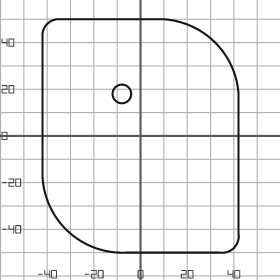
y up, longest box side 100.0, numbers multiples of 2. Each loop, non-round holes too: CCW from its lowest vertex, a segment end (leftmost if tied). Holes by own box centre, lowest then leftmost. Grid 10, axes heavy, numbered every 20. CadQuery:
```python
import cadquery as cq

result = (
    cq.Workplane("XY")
    .moveTo(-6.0, -50.0)
    .lineTo(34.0, -50.0)
    .threePointArc((40.0, -48.0), (42.0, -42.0))
    .lineTo(42.0, 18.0)
    .threePointArc((32.0, 40.0), (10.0, 50.0))
    .lineTo(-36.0, 50.0)
    .threePointArc((-40.0, 48.0), (-42.0, 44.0))
    .lineTo(-42.0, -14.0)
    .threePointArc((-32.0, -40.0), (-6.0, -50.0))
    .close()
    .moveTo(-8.0, 18.0)
    .circle(4.0)
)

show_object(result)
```